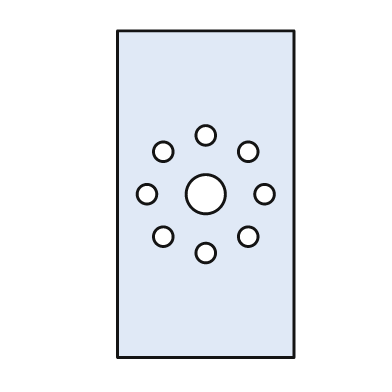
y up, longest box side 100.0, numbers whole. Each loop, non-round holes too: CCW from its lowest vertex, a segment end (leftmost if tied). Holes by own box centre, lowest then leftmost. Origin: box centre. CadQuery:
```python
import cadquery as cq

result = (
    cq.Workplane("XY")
    .moveTo(-27.0, -50.0)
    .lineTo(27.0, -50.0)
    .lineTo(27.0, 50.0)
    .lineTo(-27.0, 50.0)
    .close()
    .moveTo(0.0, -18.0)
    .circle(3.0)
    .moveTo(-13.0, -13.0)
    .circle(3.0)
    .moveTo(13.0, -13.0)
    .circle(3.0)
    .moveTo(-18.0, 0.0)
    .circle(3.0)
    .moveTo(0.0, 0.0)
    .circle(6.0)
    .moveTo(18.0, 0.0)
    .circle(3.0)
    .moveTo(-13.0, 13.0)
    .circle(3.0)
    .moveTo(13.0, 13.0)
    .circle(3.0)
    .moveTo(0.0, 18.0)
    .circle(3.0)
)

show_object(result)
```